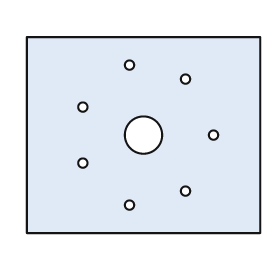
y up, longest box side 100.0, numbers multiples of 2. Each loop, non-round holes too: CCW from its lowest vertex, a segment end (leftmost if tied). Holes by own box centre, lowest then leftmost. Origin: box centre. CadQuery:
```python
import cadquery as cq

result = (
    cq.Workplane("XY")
    .moveTo(-50.0, -42.0)
    .lineTo(50.0, -42.0)
    .lineTo(50.0, 42.0)
    .lineTo(-50.0, 42.0)
    .close()
    .moveTo(-6.0, -30.0)
    .circle(2.0)
    .moveTo(18.0, -24.0)
    .circle(2.0)
    .moveTo(-26.0, -12.0)
    .circle(2.0)
    .moveTo(0.0, 0.0)
    .circle(8.0)
    .moveTo(30.0, 0.0)
    .circle(2.0)
    .moveTo(-26.0, 12.0)
    .circle(2.0)
    .moveTo(18.0, 24.0)
    .circle(2.0)
    .moveTo(-6.0, 30.0)
    .circle(2.0)
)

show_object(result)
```